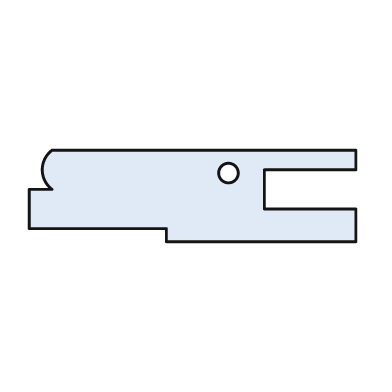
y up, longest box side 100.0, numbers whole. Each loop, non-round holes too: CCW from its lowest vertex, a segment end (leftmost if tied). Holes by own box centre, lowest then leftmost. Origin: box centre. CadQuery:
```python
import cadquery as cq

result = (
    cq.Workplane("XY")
    .moveTo(-8.0, -14.0)
    .lineTo(50.0, -14.0)
    .lineTo(50.0, -4.0)
    .lineTo(22.0, -4.0)
    .lineTo(22.0, 8.0)
    .lineTo(50.0, 8.0)
    .lineTo(50.0, 14.0)
    .lineTo(-43.0, 14.0)
    .threePointArc((-46.0, 8.0), (-43.0, 2.0))
    .lineTo(-50.0, 2.0)
    .lineTo(-50.0, -10.0)
    .lineTo(-8.0, -10.0)
    .close()
    .moveTo(11.0, 7.0)
    .circle(3.0)
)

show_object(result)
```